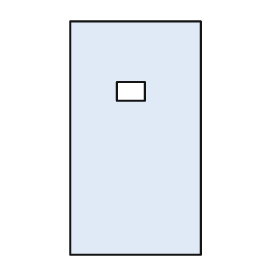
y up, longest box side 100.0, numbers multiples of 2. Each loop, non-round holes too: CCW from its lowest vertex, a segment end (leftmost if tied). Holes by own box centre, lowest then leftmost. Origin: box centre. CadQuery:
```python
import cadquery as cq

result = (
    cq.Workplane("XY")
    .moveTo(-28.0, -50.0)
    .lineTo(28.0, -50.0)
    .lineTo(28.0, 50.0)
    .lineTo(-28.0, 50.0)
    .close()
    .moveTo(-8.0, 16.0)
    .lineTo(4.0, 16.0)
    .lineTo(4.0, 24.0)
    .lineTo(-8.0, 24.0)
    .close()
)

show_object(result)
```